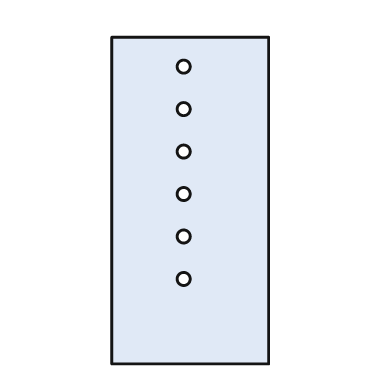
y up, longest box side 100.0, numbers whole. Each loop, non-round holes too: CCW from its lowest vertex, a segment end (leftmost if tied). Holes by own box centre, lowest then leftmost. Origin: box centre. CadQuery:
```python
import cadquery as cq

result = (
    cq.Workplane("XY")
    .moveTo(-24.0, -50.0)
    .lineTo(24.0, -50.0)
    .lineTo(24.0, 50.0)
    .lineTo(-24.0, 50.0)
    .close()
    .moveTo(-2.0, -24.0)
    .circle(2.0)
    .moveTo(-2.0, -11.0)
    .circle(2.0)
    .moveTo(-2.0, 2.0)
    .circle(2.0)
    .moveTo(-2.0, 15.0)
    .circle(2.0)
    .moveTo(-2.0, 28.0)
    .circle(2.0)
    .moveTo(-2.0, 41.0)
    .circle(2.0)
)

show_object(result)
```